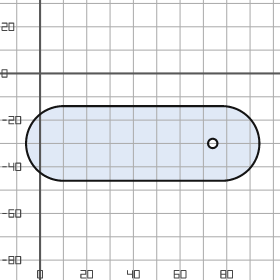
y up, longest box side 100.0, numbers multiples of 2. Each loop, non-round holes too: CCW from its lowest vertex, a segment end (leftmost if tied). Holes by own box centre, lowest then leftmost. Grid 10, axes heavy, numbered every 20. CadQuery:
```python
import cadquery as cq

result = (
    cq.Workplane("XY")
    .moveTo(10.0, -46.0)
    .lineTo(78.0, -46.0)
    .threePointArc((94.0, -30.0), (78.0, -14.0))
    .lineTo(10.0, -14.0)
    .threePointArc((-6.0, -30.0), (10.0, -46.0))
    .close()
    .moveTo(74.0, -30.0)
    .circle(2.0)
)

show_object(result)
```